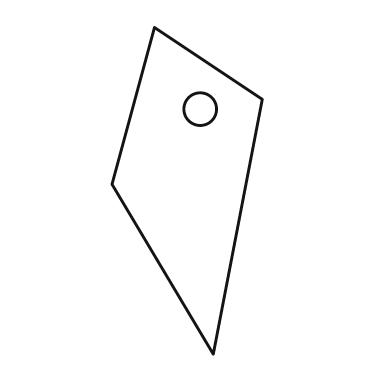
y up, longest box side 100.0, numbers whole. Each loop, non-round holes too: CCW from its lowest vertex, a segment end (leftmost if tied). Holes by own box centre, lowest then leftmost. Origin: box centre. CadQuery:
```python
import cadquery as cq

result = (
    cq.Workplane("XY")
    .moveTo(8.0, -50.0)
    .lineTo(23.0, 28.0)
    .lineTo(-10.0, 50.0)
    .lineTo(-23.0, 2.0)
    .close()
    .moveTo(4.0, 25.0)
    .circle(5.0)
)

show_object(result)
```